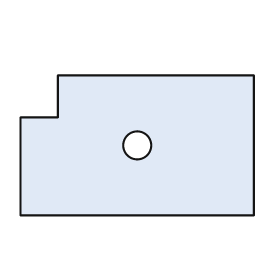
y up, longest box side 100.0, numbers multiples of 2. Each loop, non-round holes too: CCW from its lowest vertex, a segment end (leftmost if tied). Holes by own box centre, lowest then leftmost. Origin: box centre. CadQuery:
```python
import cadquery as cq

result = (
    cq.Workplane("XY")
    .moveTo(-50.0, -30.0)
    .lineTo(50.0, -30.0)
    .lineTo(50.0, 30.0)
    .lineTo(-34.0, 30.0)
    .lineTo(-34.0, 12.0)
    .lineTo(-50.0, 12.0)
    .close()
    .moveTo(0.0, 0.0)
    .circle(6.0)
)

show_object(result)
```